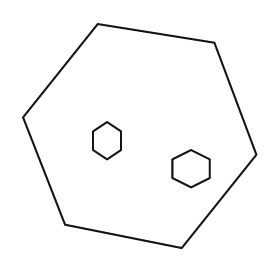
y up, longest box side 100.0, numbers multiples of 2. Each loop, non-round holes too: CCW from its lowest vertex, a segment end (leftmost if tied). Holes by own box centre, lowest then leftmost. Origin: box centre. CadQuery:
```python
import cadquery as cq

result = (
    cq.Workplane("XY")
    .moveTo(18.0, -48.0)
    .lineTo(50.0, -8.0)
    .lineTo(32.0, 40.0)
    .lineTo(-18.0, 48.0)
    .lineTo(-50.0, 8.0)
    .lineTo(-32.0, -38.0)
    .close()
    .moveTo(22.0, -22.0)
    .lineTo(30.0, -18.0)
    .lineTo(30.0, -10.0)
    .lineTo(22.0, -6.0)
    .lineTo(14.0, -10.0)
    .lineTo(14.0, -18.0)
    .close()
    .moveTo(-14.0, -10.0)
    .lineTo(-8.0, -6.0)
    .lineTo(-8.0, 2.0)
    .lineTo(-14.0, 6.0)
    .lineTo(-20.0, 2.0)
    .lineTo(-20.0, -6.0)
    .close()
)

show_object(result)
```